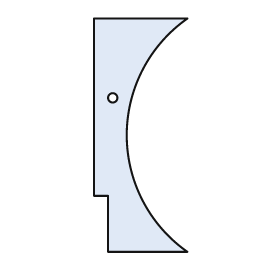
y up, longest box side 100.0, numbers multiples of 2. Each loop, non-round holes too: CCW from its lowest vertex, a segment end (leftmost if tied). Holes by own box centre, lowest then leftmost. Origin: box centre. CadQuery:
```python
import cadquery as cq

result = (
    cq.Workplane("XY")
    .moveTo(-14.0, -50.0)
    .lineTo(20.0, -50.0)
    .threePointArc((-6.0, 0.0), (20.0, 50.0))
    .lineTo(-20.0, 50.0)
    .lineTo(-20.0, -26.0)
    .lineTo(-14.0, -26.0)
    .close()
    .moveTo(-12.0, 16.0)
    .circle(2.0)
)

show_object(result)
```